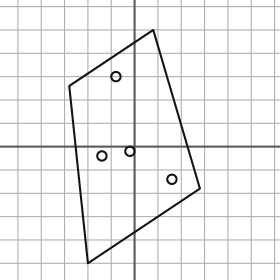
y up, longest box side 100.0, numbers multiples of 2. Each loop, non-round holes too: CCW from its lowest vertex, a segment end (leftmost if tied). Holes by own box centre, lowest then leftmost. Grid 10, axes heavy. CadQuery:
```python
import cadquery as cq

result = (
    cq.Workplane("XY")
    .moveTo(-20.0, -50.0)
    .lineTo(28.0, -18.0)
    .lineTo(8.0, 50.0)
    .lineTo(-28.0, 26.0)
    .close()
    .moveTo(16.0, -14.0)
    .circle(2.0)
    .moveTo(-14.0, -4.0)
    .circle(2.0)
    .moveTo(-2.0, -2.0)
    .circle(2.0)
    .moveTo(-8.0, 30.0)
    .circle(2.0)
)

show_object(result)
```